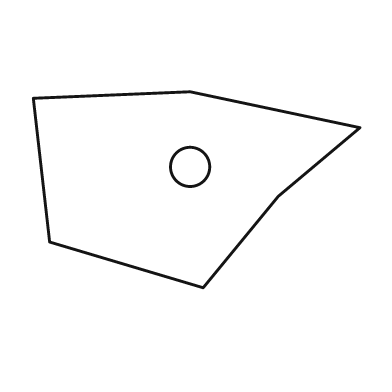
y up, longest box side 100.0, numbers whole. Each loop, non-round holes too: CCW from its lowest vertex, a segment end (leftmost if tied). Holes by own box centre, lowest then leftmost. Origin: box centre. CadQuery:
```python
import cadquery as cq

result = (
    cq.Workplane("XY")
    .moveTo(2.0, -30.0)
    .lineTo(25.0, -2.0)
    .lineTo(50.0, 19.0)
    .lineTo(-2.0, 30.0)
    .lineTo(-50.0, 28.0)
    .lineTo(-45.0, -16.0)
    .close()
    .moveTo(-2.0, 7.0)
    .circle(6.0)
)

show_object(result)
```